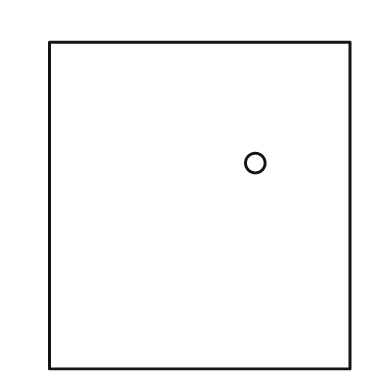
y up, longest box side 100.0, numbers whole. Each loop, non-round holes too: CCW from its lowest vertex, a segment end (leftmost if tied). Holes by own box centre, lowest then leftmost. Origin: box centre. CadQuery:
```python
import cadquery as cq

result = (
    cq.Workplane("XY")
    .moveTo(-46.0, -50.0)
    .lineTo(46.0, -50.0)
    .lineTo(46.0, 50.0)
    .lineTo(-46.0, 50.0)
    .close()
    .moveTo(17.0, 13.0)
    .circle(3.0)
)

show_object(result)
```